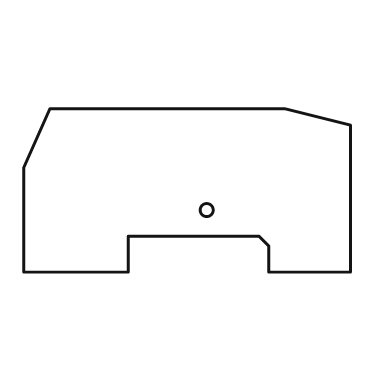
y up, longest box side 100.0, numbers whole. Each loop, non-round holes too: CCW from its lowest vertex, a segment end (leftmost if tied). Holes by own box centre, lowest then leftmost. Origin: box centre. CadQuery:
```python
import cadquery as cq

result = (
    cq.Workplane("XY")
    .moveTo(-50.0, -25.0)
    .lineTo(-18.0, -25.0)
    .lineTo(-18.0, -14.0)
    .lineTo(22.0, -14.0)
    .lineTo(25.0, -17.0)
    .lineTo(25.0, -25.0)
    .lineTo(50.0, -25.0)
    .lineTo(50.0, 20.0)
    .lineTo(30.0, 25.0)
    .lineTo(-42.0, 25.0)
    .lineTo(-50.0, 7.0)
    .close()
    .moveTo(6.0, -6.0)
    .circle(2.0)
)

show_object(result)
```